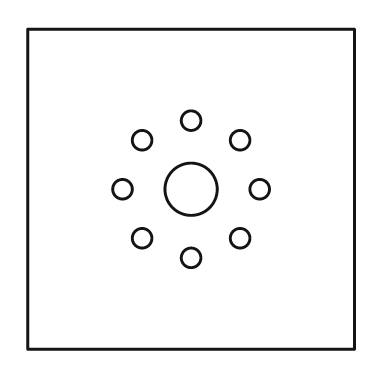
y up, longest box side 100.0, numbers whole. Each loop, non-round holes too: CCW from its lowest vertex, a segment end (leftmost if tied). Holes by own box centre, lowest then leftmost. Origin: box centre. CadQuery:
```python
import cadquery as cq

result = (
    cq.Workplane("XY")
    .moveTo(-50.0, -49.0)
    .lineTo(50.0, -49.0)
    .lineTo(50.0, 49.0)
    .lineTo(-50.0, 49.0)
    .close()
    .moveTo(0.0, -21.0)
    .circle(3.0)
    .moveTo(-15.0, -15.0)
    .circle(3.0)
    .moveTo(15.0, -15.0)
    .circle(3.0)
    .moveTo(-21.0, 0.0)
    .circle(3.0)
    .moveTo(0.0, 0.0)
    .circle(8.0)
    .moveTo(21.0, 0.0)
    .circle(3.0)
    .moveTo(-15.0, 15.0)
    .circle(3.0)
    .moveTo(15.0, 15.0)
    .circle(3.0)
    .moveTo(0.0, 21.0)
    .circle(3.0)
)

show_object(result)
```